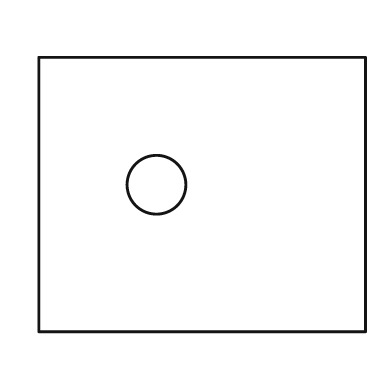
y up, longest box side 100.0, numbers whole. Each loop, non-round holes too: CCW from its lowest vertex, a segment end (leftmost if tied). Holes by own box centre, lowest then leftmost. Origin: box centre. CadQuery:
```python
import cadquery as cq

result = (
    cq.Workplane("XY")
    .moveTo(-50.0, -42.0)
    .lineTo(50.0, -42.0)
    .lineTo(50.0, 42.0)
    .lineTo(-50.0, 42.0)
    .close()
    .moveTo(-14.0, 3.0)
    .circle(9.0)
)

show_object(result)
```